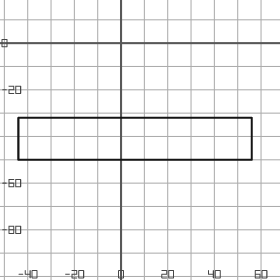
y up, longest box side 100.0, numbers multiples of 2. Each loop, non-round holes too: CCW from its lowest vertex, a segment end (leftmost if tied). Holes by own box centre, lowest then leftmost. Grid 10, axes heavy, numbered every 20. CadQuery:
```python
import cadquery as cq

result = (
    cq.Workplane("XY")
    .moveTo(-44.0, -50.0)
    .lineTo(56.0, -50.0)
    .lineTo(56.0, -32.0)
    .lineTo(-44.0, -32.0)
    .close()
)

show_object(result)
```